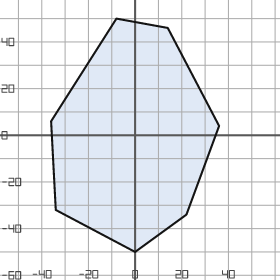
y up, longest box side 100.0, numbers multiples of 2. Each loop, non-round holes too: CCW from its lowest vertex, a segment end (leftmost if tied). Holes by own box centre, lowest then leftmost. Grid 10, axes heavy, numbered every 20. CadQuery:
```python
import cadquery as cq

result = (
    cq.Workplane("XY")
    .moveTo(0.0, -50.0)
    .lineTo(22.0, -34.0)
    .lineTo(36.0, 4.0)
    .lineTo(14.0, 46.0)
    .lineTo(-8.0, 50.0)
    .lineTo(-36.0, 6.0)
    .lineTo(-34.0, -32.0)
    .close()
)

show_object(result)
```